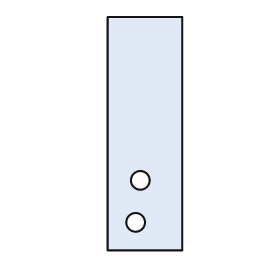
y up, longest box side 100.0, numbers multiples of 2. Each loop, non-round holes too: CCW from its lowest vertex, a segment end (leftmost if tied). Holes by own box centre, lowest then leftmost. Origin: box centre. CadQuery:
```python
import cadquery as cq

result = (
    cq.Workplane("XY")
    .moveTo(-16.0, -50.0)
    .lineTo(16.0, -50.0)
    .lineTo(16.0, 50.0)
    .lineTo(-16.0, 50.0)
    .close()
    .moveTo(-4.0, -38.0)
    .circle(4.0)
    .moveTo(-2.0, -20.0)
    .circle(4.0)
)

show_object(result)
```